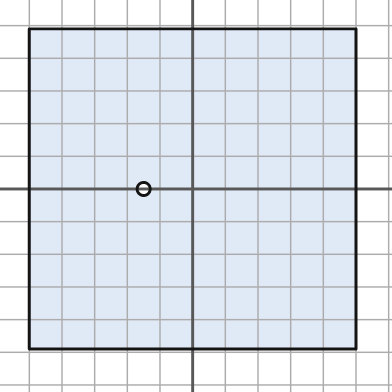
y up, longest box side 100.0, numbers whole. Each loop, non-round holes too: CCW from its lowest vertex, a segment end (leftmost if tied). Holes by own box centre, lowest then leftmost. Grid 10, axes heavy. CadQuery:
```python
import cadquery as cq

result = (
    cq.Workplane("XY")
    .moveTo(-50.0, -49.0)
    .lineTo(50.0, -49.0)
    .lineTo(50.0, 49.0)
    .lineTo(-50.0, 49.0)
    .close()
    .moveTo(-15.0, 0.0)
    .circle(2.0)
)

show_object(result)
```